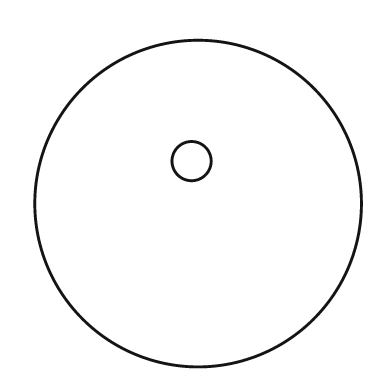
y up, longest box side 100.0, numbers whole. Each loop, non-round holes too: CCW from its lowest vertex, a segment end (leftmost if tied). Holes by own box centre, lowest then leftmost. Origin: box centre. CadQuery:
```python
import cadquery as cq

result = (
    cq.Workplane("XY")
    .moveTo(0.0, 0.0)
    .circle(50.0)
    .moveTo(-2.0, 13.0)
    .circle(6.0)
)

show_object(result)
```